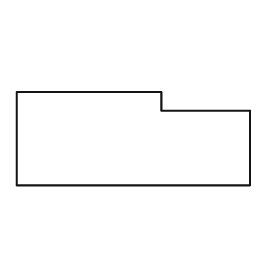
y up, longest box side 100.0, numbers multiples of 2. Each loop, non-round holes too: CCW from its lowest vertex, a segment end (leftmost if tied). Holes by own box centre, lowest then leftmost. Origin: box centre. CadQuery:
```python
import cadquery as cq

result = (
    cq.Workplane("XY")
    .moveTo(-50.0, -20.0)
    .lineTo(50.0, -20.0)
    .lineTo(50.0, 12.0)
    .lineTo(12.0, 12.0)
    .lineTo(12.0, 20.0)
    .lineTo(-50.0, 20.0)
    .close()
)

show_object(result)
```